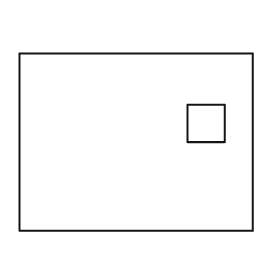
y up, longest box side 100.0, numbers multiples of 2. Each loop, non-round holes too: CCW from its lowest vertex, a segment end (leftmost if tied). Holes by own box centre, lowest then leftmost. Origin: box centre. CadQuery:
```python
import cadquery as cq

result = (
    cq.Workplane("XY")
    .moveTo(-50.0, -38.0)
    .lineTo(50.0, -38.0)
    .lineTo(50.0, 38.0)
    .lineTo(-50.0, 38.0)
    .close()
    .moveTo(22.0, 0.0)
    .lineTo(38.0, 0.0)
    .lineTo(38.0, 16.0)
    .lineTo(22.0, 16.0)
    .close()
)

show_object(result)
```